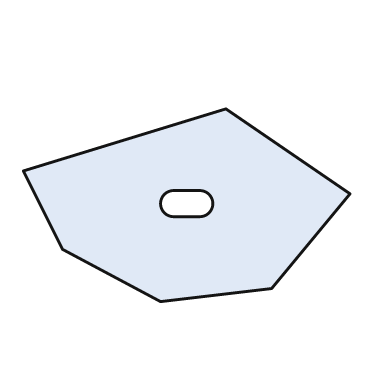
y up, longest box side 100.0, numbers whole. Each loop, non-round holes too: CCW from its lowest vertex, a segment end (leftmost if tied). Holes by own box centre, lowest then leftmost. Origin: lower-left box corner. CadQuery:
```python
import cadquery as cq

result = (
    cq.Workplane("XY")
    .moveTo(42.0, 0.0)
    .lineTo(76.0, 4.0)
    .lineTo(100.0, 33.0)
    .lineTo(62.0, 59.0)
    .lineTo(0.0, 40.0)
    .lineTo(12.0, 16.0)
    .close()
    .moveTo(46.0, 26.0)
    .lineTo(54.0, 26.0)
    .threePointArc((58.0, 30.0), (54.0, 34.0))
    .lineTo(46.0, 34.0)
    .threePointArc((42.0, 30.0), (46.0, 26.0))
    .close()
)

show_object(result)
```